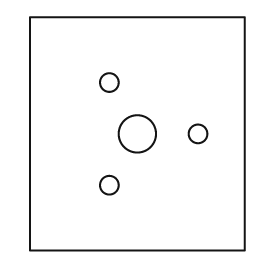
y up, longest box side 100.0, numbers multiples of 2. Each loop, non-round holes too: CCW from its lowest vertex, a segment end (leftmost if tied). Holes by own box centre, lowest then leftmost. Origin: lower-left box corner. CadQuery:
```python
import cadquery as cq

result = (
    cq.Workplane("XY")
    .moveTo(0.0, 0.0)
    .lineTo(92.0, 0.0)
    .lineTo(92.0, 100.0)
    .lineTo(0.0, 100.0)
    .close()
    .moveTo(34.0, 28.0)
    .circle(4.0)
    .moveTo(46.0, 50.0)
    .circle(8.0)
    .moveTo(72.0, 50.0)
    .circle(4.0)
    .moveTo(34.0, 72.0)
    .circle(4.0)
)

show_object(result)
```